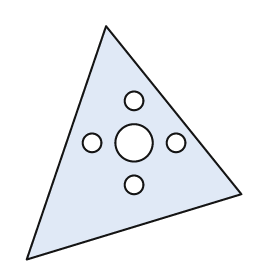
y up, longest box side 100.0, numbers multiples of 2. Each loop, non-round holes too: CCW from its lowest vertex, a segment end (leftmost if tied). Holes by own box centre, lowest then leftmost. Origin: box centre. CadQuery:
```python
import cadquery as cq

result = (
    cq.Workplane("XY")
    .moveTo(-46.0, -50.0)
    .lineTo(46.0, -22.0)
    .lineTo(-12.0, 50.0)
    .close()
    .moveTo(0.0, -18.0)
    .circle(4.0)
    .moveTo(-18.0, 0.0)
    .circle(4.0)
    .moveTo(0.0, 0.0)
    .circle(8.0)
    .moveTo(18.0, 0.0)
    .circle(4.0)
    .moveTo(0.0, 18.0)
    .circle(4.0)
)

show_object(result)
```